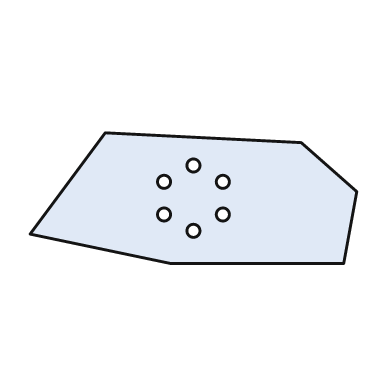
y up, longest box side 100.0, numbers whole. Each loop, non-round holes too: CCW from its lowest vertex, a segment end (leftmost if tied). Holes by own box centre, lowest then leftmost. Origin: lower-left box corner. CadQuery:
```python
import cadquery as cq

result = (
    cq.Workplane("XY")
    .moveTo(43.0, 0.0)
    .lineTo(96.0, 0.0)
    .lineTo(100.0, 22.0)
    .lineTo(83.0, 37.0)
    .lineTo(23.0, 40.0)
    .lineTo(0.0, 9.0)
    .close()
    .moveTo(50.0, 10.0)
    .circle(2.0)
    .moveTo(41.0, 15.0)
    .circle(2.0)
    .moveTo(59.0, 15.0)
    .circle(2.0)
    .moveTo(41.0, 25.0)
    .circle(2.0)
    .moveTo(59.0, 25.0)
    .circle(2.0)
    .moveTo(50.0, 30.0)
    .circle(2.0)
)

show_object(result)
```